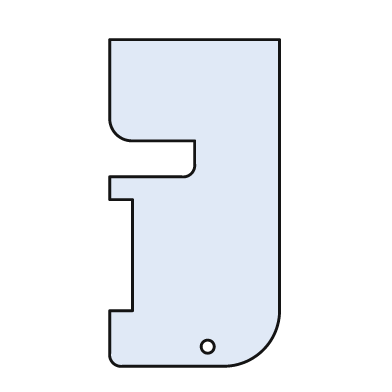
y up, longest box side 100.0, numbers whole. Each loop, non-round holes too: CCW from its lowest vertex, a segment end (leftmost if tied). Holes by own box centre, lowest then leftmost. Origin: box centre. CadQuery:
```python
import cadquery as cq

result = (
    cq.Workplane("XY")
    .moveTo(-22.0, -50.0)
    .lineTo(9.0, -50.0)
    .threePointArc((21.0, -45.0), (26.0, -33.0))
    .lineTo(26.0, 50.0)
    .lineTo(-26.0, 50.0)
    .lineTo(-26.0, 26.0)
    .threePointArc((-24.0, 21.0), (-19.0, 19.0))
    .lineTo(0.0, 19.0)
    .lineTo(0.0, 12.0)
    .threePointArc((-1.0, 9.0), (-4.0, 8.0))
    .lineTo(-26.0, 8.0)
    .lineTo(-26.0, 1.0)
    .lineTo(-19.0, 1.0)
    .lineTo(-19.0, -33.0)
    .lineTo(-26.0, -33.0)
    .lineTo(-26.0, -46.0)
    .threePointArc((-25.0, -49.0), (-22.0, -50.0))
    .close()
    .moveTo(4.0, -44.0)
    .circle(2.0)
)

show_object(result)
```